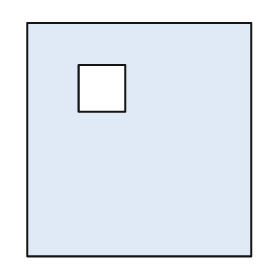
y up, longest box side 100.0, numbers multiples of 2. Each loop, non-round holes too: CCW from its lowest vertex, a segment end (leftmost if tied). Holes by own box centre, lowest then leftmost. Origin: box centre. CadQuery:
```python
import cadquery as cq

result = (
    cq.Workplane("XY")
    .moveTo(-48.0, -50.0)
    .lineTo(48.0, -50.0)
    .lineTo(48.0, 50.0)
    .lineTo(-48.0, 50.0)
    .close()
    .moveTo(-26.0, 12.0)
    .lineTo(-6.0, 12.0)
    .lineTo(-6.0, 32.0)
    .lineTo(-26.0, 32.0)
    .close()
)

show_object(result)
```